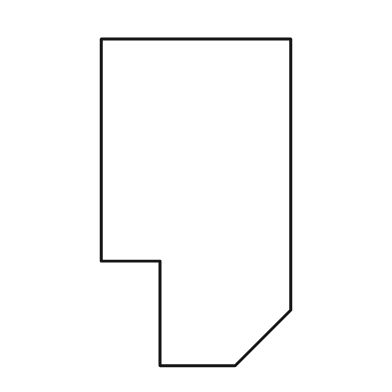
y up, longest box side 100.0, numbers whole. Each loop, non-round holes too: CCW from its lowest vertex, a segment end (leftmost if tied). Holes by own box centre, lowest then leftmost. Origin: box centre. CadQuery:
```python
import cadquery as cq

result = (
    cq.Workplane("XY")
    .moveTo(-11.0, -50.0)
    .lineTo(12.0, -50.0)
    .lineTo(29.0, -33.0)
    .lineTo(29.0, 50.0)
    .lineTo(-29.0, 50.0)
    .lineTo(-29.0, -18.0)
    .lineTo(-11.0, -18.0)
    .close()
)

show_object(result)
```